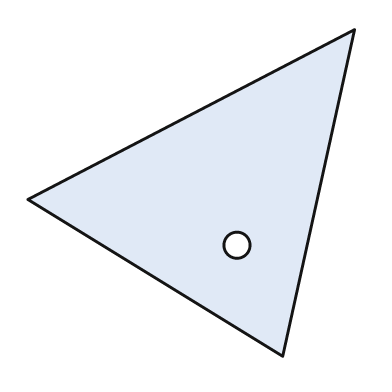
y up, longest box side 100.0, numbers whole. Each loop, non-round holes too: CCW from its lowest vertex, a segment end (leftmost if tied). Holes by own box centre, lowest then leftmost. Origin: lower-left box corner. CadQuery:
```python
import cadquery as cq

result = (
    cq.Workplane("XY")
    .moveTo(78.0, 0.0)
    .lineTo(100.0, 100.0)
    .lineTo(0.0, 48.0)
    .close()
    .moveTo(64.0, 34.0)
    .circle(4.0)
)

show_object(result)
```